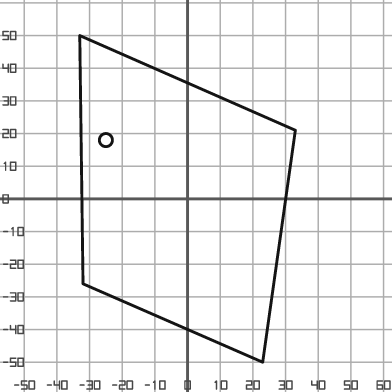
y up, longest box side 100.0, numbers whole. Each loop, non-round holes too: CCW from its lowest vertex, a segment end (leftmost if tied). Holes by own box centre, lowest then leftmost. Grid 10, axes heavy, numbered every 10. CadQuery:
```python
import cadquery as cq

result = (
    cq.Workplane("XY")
    .moveTo(23.0, -50.0)
    .lineTo(33.0, 21.0)
    .lineTo(-33.0, 50.0)
    .lineTo(-32.0, -26.0)
    .close()
    .moveTo(-25.0, 18.0)
    .circle(2.0)
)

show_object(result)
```